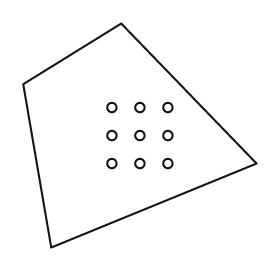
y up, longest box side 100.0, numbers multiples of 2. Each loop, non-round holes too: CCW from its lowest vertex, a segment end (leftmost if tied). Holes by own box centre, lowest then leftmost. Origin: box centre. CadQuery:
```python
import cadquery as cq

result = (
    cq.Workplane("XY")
    .moveTo(-38.0, -48.0)
    .lineTo(50.0, -12.0)
    .lineTo(-8.0, 48.0)
    .lineTo(-50.0, 22.0)
    .close()
    .moveTo(-12.0, -12.0)
    .circle(2.0)
    .moveTo(0.0, -12.0)
    .circle(2.0)
    .moveTo(12.0, -12.0)
    .circle(2.0)
    .moveTo(-12.0, 0.0)
    .circle(2.0)
    .moveTo(0.0, 0.0)
    .circle(2.0)
    .moveTo(12.0, 0.0)
    .circle(2.0)
    .moveTo(-12.0, 12.0)
    .circle(2.0)
    .moveTo(0.0, 12.0)
    .circle(2.0)
    .moveTo(12.0, 12.0)
    .circle(2.0)
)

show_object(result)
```